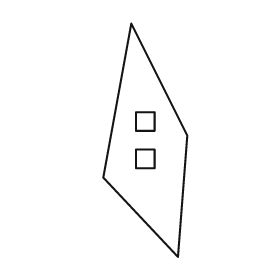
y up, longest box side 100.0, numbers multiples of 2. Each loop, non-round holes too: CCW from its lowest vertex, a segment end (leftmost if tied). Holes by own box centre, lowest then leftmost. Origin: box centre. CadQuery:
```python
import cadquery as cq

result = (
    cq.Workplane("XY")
    .moveTo(14.0, -50.0)
    .lineTo(18.0, 2.0)
    .lineTo(-6.0, 50.0)
    .lineTo(-18.0, -16.0)
    .close()
    .moveTo(-4.0, -12.0)
    .lineTo(4.0, -12.0)
    .lineTo(4.0, -4.0)
    .lineTo(-4.0, -4.0)
    .close()
    .moveTo(-4.0, 4.0)
    .lineTo(4.0, 4.0)
    .lineTo(4.0, 12.0)
    .lineTo(-4.0, 12.0)
    .close()
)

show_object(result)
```